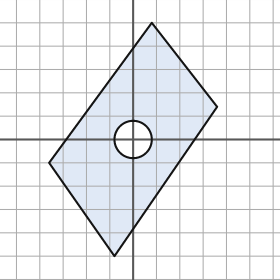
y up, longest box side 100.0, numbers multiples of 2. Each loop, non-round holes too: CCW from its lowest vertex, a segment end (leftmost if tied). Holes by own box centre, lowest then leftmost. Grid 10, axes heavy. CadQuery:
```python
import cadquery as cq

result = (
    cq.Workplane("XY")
    .moveTo(-8.0, -50.0)
    .lineTo(36.0, 14.0)
    .lineTo(8.0, 50.0)
    .lineTo(-36.0, -10.0)
    .close()
    .moveTo(0.0, 0.0)
    .circle(8.0)
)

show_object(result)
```